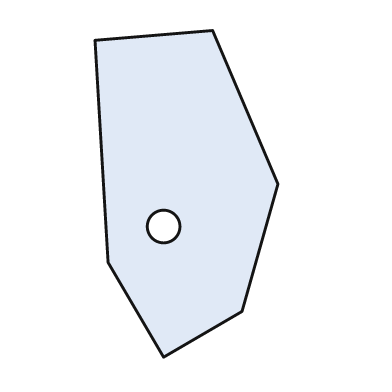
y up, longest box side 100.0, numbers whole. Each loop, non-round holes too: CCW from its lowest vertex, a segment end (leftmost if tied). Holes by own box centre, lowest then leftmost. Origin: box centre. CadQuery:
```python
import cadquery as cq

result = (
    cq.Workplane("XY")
    .moveTo(-7.0, -50.0)
    .lineTo(17.0, -36.0)
    .lineTo(28.0, 3.0)
    .lineTo(8.0, 50.0)
    .lineTo(-28.0, 47.0)
    .lineTo(-24.0, -21.0)
    .close()
    .moveTo(-7.0, -10.0)
    .circle(5.0)
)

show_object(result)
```